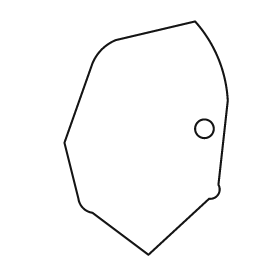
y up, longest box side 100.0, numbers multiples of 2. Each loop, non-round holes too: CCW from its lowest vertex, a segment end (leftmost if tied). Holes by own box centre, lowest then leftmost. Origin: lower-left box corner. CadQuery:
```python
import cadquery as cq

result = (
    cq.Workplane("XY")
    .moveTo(36.0, 0.0)
    .lineTo(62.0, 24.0)
    .threePointArc((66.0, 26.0), (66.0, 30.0))
    .lineTo(70.0, 66.0)
    .threePointArc((66.0, 84.0), (56.0, 100.0))
    .lineTo(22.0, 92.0)
    .threePointArc((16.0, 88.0), (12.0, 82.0))
    .lineTo(0.0, 48.0)
    .lineTo(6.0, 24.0)
    .threePointArc((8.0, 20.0), (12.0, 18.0))
    .close()
    .moveTo(60.0, 54.0)
    .circle(4.0)
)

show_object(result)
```